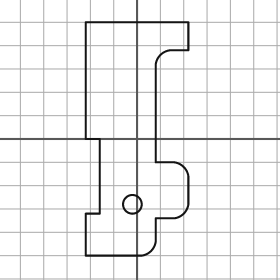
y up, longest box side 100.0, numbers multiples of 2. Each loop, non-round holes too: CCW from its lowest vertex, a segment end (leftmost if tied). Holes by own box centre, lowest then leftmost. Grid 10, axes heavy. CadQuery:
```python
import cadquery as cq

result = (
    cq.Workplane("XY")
    .moveTo(-22.0, -50.0)
    .lineTo(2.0, -50.0)
    .threePointArc((6.0, -48.0), (8.0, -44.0))
    .lineTo(8.0, -34.0)
    .lineTo(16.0, -34.0)
    .threePointArc((20.0, -32.0), (22.0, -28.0))
    .lineTo(22.0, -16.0)
    .threePointArc((20.0, -12.0), (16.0, -10.0))
    .lineTo(8.0, -10.0)
    .lineTo(8.0, 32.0)
    .threePointArc((10.0, 36.0), (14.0, 38.0))
    .lineTo(22.0, 38.0)
    .lineTo(22.0, 50.0)
    .lineTo(-22.0, 50.0)
    .lineTo(-22.0, 0.0)
    .lineTo(-16.0, 0.0)
    .lineTo(-16.0, -32.0)
    .lineTo(-22.0, -32.0)
    .close()
    .moveTo(-2.0, -28.0)
    .circle(4.0)
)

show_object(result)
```